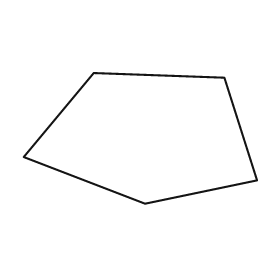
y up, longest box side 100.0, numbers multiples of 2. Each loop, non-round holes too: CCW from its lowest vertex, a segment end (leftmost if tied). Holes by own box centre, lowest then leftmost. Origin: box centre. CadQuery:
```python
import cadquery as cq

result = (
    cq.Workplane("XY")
    .moveTo(2.0, -28.0)
    .lineTo(50.0, -18.0)
    .lineTo(36.0, 26.0)
    .lineTo(-20.0, 28.0)
    .lineTo(-50.0, -8.0)
    .close()
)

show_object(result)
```